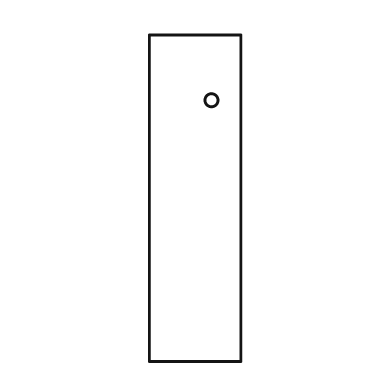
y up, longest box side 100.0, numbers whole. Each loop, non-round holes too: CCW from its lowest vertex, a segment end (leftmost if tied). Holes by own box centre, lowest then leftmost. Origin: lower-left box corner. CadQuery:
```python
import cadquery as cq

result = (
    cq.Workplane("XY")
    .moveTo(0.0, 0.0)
    .lineTo(28.0, 0.0)
    .lineTo(28.0, 100.0)
    .lineTo(0.0, 100.0)
    .close()
    .moveTo(19.0, 80.0)
    .circle(2.0)
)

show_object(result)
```